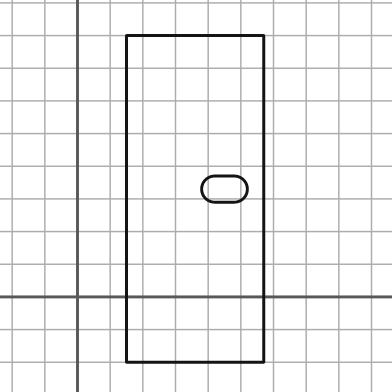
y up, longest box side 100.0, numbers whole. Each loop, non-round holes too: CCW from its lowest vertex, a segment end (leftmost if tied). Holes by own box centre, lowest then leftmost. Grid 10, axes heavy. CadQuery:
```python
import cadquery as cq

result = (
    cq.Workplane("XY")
    .moveTo(15.0, -20.0)
    .lineTo(57.0, -20.0)
    .lineTo(57.0, 80.0)
    .lineTo(15.0, 80.0)
    .close()
    .moveTo(42.0, 29.0)
    .lineTo(48.0, 29.0)
    .threePointArc((52.0, 33.0), (48.0, 37.0))
    .lineTo(42.0, 37.0)
    .threePointArc((38.0, 33.0), (42.0, 29.0))
    .close()
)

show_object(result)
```